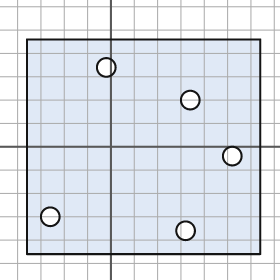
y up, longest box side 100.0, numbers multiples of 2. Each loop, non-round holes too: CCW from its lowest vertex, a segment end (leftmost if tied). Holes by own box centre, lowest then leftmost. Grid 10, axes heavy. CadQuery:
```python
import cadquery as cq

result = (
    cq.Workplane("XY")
    .moveTo(-36.0, -46.0)
    .lineTo(64.0, -46.0)
    .lineTo(64.0, 46.0)
    .lineTo(-36.0, 46.0)
    .close()
    .moveTo(32.0, -36.0)
    .circle(4.0)
    .moveTo(-26.0, -30.0)
    .circle(4.0)
    .moveTo(52.0, -4.0)
    .circle(4.0)
    .moveTo(34.0, 20.0)
    .circle(4.0)
    .moveTo(-2.0, 34.0)
    .circle(4.0)
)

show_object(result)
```